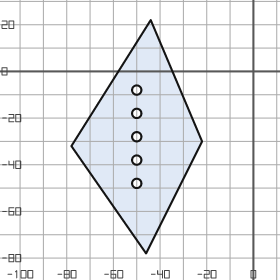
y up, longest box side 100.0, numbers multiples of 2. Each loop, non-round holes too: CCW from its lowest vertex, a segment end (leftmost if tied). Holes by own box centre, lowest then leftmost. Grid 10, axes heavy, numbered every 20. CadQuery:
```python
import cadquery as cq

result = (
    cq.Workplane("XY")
    .moveTo(-46.0, -78.0)
    .lineTo(-22.0, -30.0)
    .lineTo(-44.0, 22.0)
    .lineTo(-78.0, -32.0)
    .close()
    .moveTo(-50.0, -48.0)
    .circle(2.0)
    .moveTo(-50.0, -38.0)
    .circle(2.0)
    .moveTo(-50.0, -28.0)
    .circle(2.0)
    .moveTo(-50.0, -18.0)
    .circle(2.0)
    .moveTo(-50.0, -8.0)
    .circle(2.0)
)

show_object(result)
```